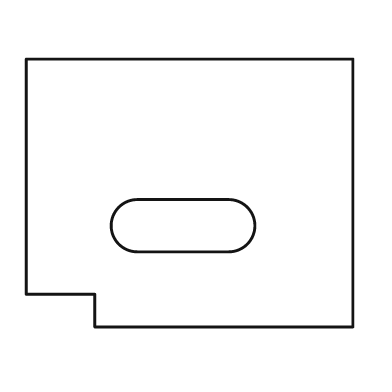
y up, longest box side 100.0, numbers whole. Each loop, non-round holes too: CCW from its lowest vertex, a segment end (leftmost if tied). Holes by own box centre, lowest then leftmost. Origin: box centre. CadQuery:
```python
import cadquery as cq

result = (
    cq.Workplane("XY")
    .moveTo(-29.0, -41.0)
    .lineTo(50.0, -41.0)
    .lineTo(50.0, 41.0)
    .lineTo(-50.0, 41.0)
    .lineTo(-50.0, -31.0)
    .lineTo(-29.0, -31.0)
    .close()
    .moveTo(-16.0, -18.0)
    .lineTo(12.0, -18.0)
    .threePointArc((20.0, -10.0), (12.0, -2.0))
    .lineTo(-16.0, -2.0)
    .threePointArc((-24.0, -10.0), (-16.0, -18.0))
    .close()
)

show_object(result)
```